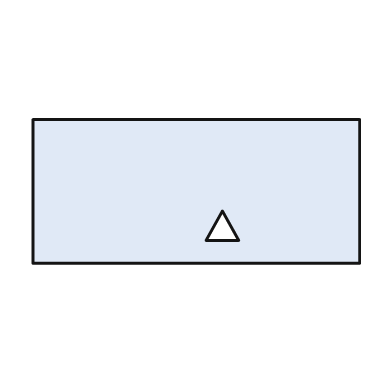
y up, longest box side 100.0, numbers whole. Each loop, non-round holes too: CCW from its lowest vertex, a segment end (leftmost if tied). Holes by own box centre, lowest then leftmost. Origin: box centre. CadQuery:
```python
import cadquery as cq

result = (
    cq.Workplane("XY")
    .moveTo(-50.0, -22.0)
    .lineTo(50.0, -22.0)
    .lineTo(50.0, 22.0)
    .lineTo(-50.0, 22.0)
    .close()
    .moveTo(3.0, -15.0)
    .lineTo(13.0, -15.0)
    .lineTo(8.0, -6.0)
    .close()
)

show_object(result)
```